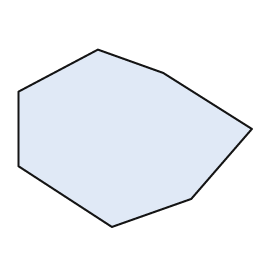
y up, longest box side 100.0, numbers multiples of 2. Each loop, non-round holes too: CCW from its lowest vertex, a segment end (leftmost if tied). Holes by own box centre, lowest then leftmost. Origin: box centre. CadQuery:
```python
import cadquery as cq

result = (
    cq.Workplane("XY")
    .moveTo(-10.0, -38.0)
    .lineTo(24.0, -26.0)
    .lineTo(50.0, 4.0)
    .lineTo(12.0, 28.0)
    .lineTo(-16.0, 38.0)
    .lineTo(-50.0, 20.0)
    .lineTo(-50.0, -12.0)
    .close()
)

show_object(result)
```